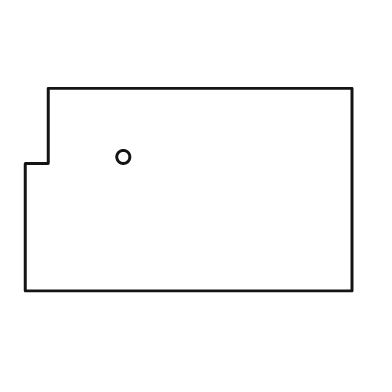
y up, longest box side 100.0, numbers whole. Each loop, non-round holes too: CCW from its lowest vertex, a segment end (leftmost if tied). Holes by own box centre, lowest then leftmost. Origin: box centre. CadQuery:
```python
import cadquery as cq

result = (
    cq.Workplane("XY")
    .moveTo(-50.0, -31.0)
    .lineTo(50.0, -31.0)
    .lineTo(50.0, 31.0)
    .lineTo(-43.0, 31.0)
    .lineTo(-43.0, 8.0)
    .lineTo(-50.0, 8.0)
    .close()
    .moveTo(-20.0, 10.0)
    .circle(2.0)
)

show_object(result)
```